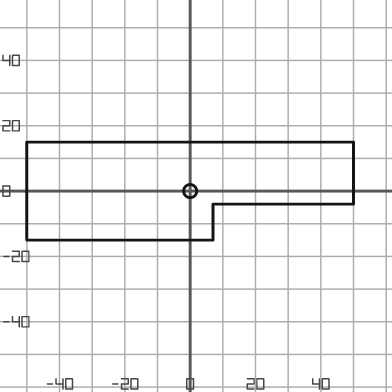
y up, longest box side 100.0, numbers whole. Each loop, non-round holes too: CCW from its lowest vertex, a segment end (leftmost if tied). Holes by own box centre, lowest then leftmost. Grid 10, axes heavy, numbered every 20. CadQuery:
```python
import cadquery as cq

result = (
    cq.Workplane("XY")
    .moveTo(-50.0, -15.0)
    .lineTo(7.0, -15.0)
    .lineTo(7.0, -4.0)
    .lineTo(50.0, -4.0)
    .lineTo(50.0, 15.0)
    .lineTo(-50.0, 15.0)
    .close()
    .moveTo(0.0, 0.0)
    .circle(2.0)
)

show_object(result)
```